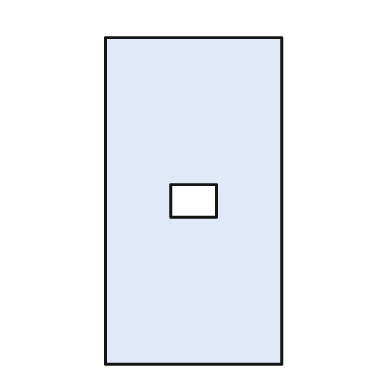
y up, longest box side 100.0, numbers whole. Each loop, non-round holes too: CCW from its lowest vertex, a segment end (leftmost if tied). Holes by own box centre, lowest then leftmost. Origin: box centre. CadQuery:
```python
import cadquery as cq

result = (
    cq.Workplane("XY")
    .moveTo(-27.0, -50.0)
    .lineTo(27.0, -50.0)
    .lineTo(27.0, 50.0)
    .lineTo(-27.0, 50.0)
    .close()
    .moveTo(-7.0, -5.0)
    .lineTo(7.0, -5.0)
    .lineTo(7.0, 5.0)
    .lineTo(-7.0, 5.0)
    .close()
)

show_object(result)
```